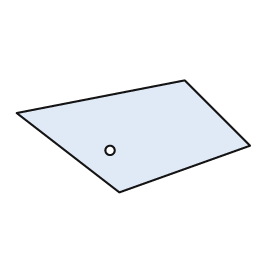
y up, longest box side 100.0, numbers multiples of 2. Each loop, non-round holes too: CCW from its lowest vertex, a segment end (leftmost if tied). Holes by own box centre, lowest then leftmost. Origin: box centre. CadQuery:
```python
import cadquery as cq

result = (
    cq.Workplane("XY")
    .moveTo(-6.0, -24.0)
    .lineTo(50.0, -4.0)
    .lineTo(22.0, 24.0)
    .lineTo(-50.0, 10.0)
    .close()
    .moveTo(-10.0, -6.0)
    .circle(2.0)
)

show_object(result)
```